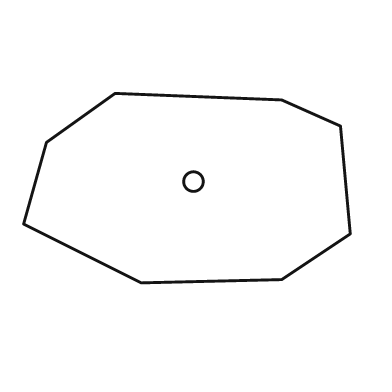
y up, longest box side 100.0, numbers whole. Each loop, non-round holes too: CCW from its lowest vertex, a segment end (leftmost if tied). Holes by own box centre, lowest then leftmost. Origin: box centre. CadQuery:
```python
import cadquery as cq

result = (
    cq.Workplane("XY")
    .moveTo(-14.0, -29.0)
    .lineTo(29.0, -28.0)
    .lineTo(50.0, -14.0)
    .lineTo(47.0, 19.0)
    .lineTo(29.0, 27.0)
    .lineTo(-22.0, 29.0)
    .lineTo(-43.0, 14.0)
    .lineTo(-50.0, -11.0)
    .close()
    .moveTo(2.0, 2.0)
    .circle(3.0)
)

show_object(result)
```